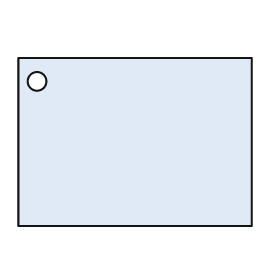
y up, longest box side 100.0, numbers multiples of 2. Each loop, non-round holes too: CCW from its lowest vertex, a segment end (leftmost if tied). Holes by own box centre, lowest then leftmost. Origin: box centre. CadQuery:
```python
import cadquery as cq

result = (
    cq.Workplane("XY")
    .moveTo(-50.0, -36.0)
    .lineTo(50.0, -36.0)
    .lineTo(50.0, 36.0)
    .lineTo(-50.0, 36.0)
    .close()
    .moveTo(-42.0, 26.0)
    .circle(4.0)
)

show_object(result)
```